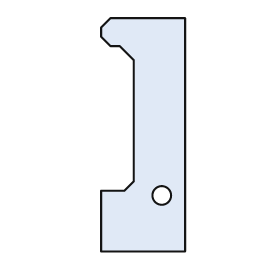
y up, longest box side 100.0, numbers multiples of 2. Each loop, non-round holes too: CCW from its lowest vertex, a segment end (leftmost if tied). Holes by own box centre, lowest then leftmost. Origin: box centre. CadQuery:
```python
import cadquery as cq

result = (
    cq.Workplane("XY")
    .moveTo(-18.0, -50.0)
    .lineTo(18.0, -50.0)
    .lineTo(18.0, 50.0)
    .lineTo(-14.0, 50.0)
    .lineTo(-18.0, 46.0)
    .lineTo(-18.0, 42.0)
    .lineTo(-14.0, 38.0)
    .lineTo(-10.0, 38.0)
    .lineTo(-4.0, 32.0)
    .lineTo(-4.0, -20.0)
    .lineTo(-8.0, -24.0)
    .lineTo(-18.0, -24.0)
    .close()
    .moveTo(8.0, -26.0)
    .circle(4.0)
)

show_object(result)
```